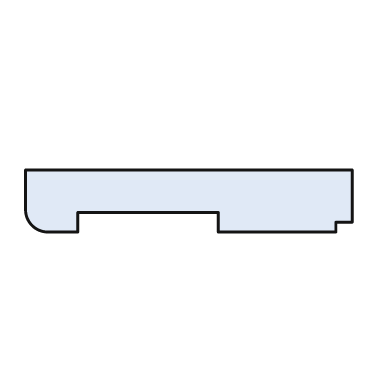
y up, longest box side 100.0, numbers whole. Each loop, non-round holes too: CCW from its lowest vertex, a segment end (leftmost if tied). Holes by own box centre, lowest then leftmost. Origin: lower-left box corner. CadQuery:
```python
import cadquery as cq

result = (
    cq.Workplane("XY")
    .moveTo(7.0, 0.0)
    .lineTo(16.0, 0.0)
    .lineTo(16.0, 6.0)
    .lineTo(59.0, 6.0)
    .lineTo(59.0, 0.0)
    .lineTo(95.0, 0.0)
    .lineTo(95.0, 3.0)
    .lineTo(100.0, 3.0)
    .lineTo(100.0, 19.0)
    .lineTo(0.0, 19.0)
    .lineTo(0.0, 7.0)
    .threePointArc((2.0, 2.0), (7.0, 0.0))
    .close()
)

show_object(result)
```